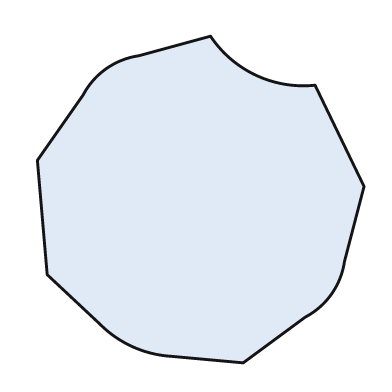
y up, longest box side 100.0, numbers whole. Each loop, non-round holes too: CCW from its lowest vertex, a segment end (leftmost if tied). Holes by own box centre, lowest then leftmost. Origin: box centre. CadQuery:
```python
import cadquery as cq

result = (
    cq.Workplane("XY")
    .moveTo(13.0, -50.0)
    .lineTo(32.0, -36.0)
    .threePointArc((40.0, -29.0), (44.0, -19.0))
    .lineTo(50.0, 4.0)
    .lineTo(35.0, 35.0)
    .threePointArc((17.0, 38.0), (3.0, 50.0))
    .lineTo(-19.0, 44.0)
    .threePointArc((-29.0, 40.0), (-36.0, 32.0))
    .lineTo(-50.0, 12.0)
    .lineTo(-47.0, -23.0)
    .lineTo(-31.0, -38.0)
    .threePointArc((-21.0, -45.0), (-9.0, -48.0))
    .close()
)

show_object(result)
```